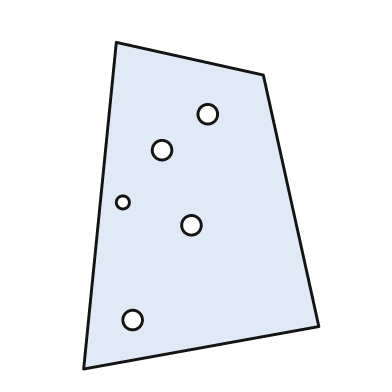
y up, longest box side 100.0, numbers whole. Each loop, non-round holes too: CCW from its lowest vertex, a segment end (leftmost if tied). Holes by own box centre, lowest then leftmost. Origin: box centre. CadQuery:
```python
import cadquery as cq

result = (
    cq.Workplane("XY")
    .moveTo(-36.0, -50.0)
    .lineTo(36.0, -37.0)
    .lineTo(19.0, 40.0)
    .lineTo(-26.0, 50.0)
    .close()
    .moveTo(-21.0, -35.0)
    .circle(3.0)
    .moveTo(-3.0, -6.0)
    .circle(3.0)
    .moveTo(-24.0, 1.0)
    .circle(2.0)
    .moveTo(-12.0, 17.0)
    .circle(3.0)
    .moveTo(2.0, 28.0)
    .circle(3.0)
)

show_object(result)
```